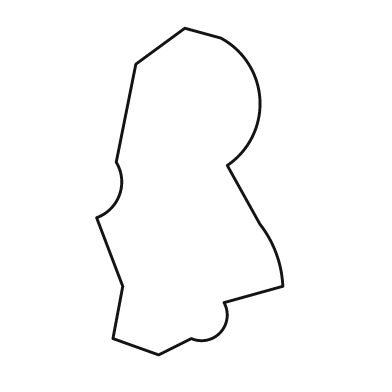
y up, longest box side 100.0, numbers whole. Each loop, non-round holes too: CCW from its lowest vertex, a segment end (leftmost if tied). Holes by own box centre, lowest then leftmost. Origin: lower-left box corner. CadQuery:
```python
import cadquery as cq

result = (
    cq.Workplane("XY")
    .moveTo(19.0, 0.0)
    .lineTo(29.0, 5.0)
    .threePointArc((38.0, 7.0), (39.0, 16.0))
    .lineTo(57.0, 21.0)
    .threePointArc((55.0, 31.0), (50.0, 40.0))
    .lineTo(40.0, 58.0)
    .threePointArc((50.0, 78.0), (38.0, 97.0))
    .lineTo(27.0, 100.0)
    .lineTo(12.0, 89.0)
    .lineTo(6.0, 59.0)
    .threePointArc((7.0, 49.0), (0.0, 42.0))
    .lineTo(8.0, 21.0)
    .lineTo(5.0, 5.0)
    .close()
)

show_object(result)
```